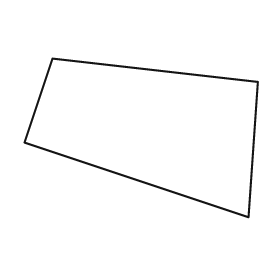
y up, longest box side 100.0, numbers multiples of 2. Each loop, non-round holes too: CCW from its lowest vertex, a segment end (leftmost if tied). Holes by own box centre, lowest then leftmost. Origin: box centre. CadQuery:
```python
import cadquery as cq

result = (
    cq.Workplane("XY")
    .moveTo(46.0, -34.0)
    .lineTo(50.0, 24.0)
    .lineTo(-38.0, 34.0)
    .lineTo(-50.0, -2.0)
    .close()
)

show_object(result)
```